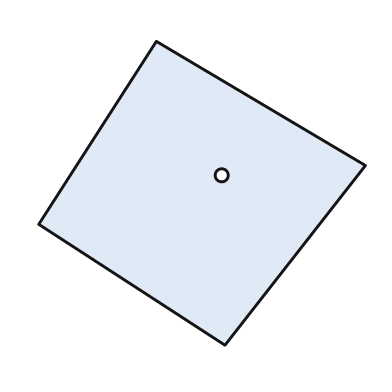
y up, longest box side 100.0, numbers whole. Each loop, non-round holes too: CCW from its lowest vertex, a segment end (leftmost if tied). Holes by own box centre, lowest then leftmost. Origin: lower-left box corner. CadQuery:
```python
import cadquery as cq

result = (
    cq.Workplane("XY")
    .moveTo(57.0, 0.0)
    .lineTo(100.0, 55.0)
    .lineTo(36.0, 93.0)
    .lineTo(0.0, 37.0)
    .close()
    .moveTo(56.0, 52.0)
    .circle(2.0)
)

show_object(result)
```